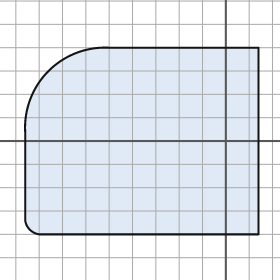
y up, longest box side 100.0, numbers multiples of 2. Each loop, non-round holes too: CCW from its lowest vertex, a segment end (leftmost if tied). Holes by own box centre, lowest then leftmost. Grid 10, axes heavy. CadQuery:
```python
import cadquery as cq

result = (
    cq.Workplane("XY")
    .moveTo(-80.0, -40.0)
    .lineTo(14.0, -40.0)
    .lineTo(14.0, 40.0)
    .lineTo(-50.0, 40.0)
    .threePointArc((-76.0, 30.0), (-86.0, 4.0))
    .lineTo(-86.0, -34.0)
    .threePointArc((-84.0, -38.0), (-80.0, -40.0))
    .close()
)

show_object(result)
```